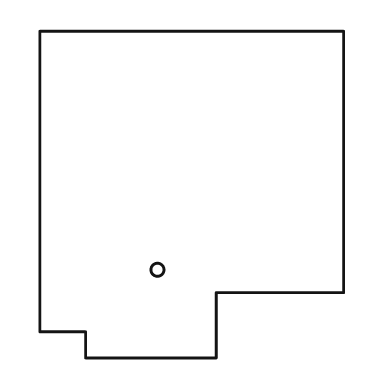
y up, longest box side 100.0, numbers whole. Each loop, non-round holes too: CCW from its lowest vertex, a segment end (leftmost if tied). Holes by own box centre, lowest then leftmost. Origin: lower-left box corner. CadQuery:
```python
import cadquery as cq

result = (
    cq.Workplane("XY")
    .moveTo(14.0, 0.0)
    .lineTo(54.0, 0.0)
    .lineTo(54.0, 20.0)
    .lineTo(93.0, 20.0)
    .lineTo(93.0, 100.0)
    .lineTo(0.0, 100.0)
    .lineTo(0.0, 8.0)
    .lineTo(14.0, 8.0)
    .close()
    .moveTo(36.0, 27.0)
    .circle(2.0)
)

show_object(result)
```